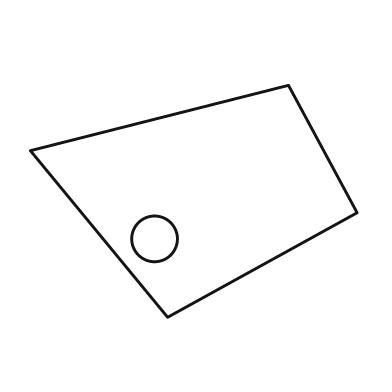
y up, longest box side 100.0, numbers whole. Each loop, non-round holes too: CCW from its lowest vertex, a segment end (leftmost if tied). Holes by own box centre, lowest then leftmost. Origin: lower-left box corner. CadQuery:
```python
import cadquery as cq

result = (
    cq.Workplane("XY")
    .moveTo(42.0, 0.0)
    .lineTo(100.0, 32.0)
    .lineTo(79.0, 71.0)
    .lineTo(0.0, 51.0)
    .close()
    .moveTo(38.0, 24.0)
    .circle(7.0)
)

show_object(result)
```